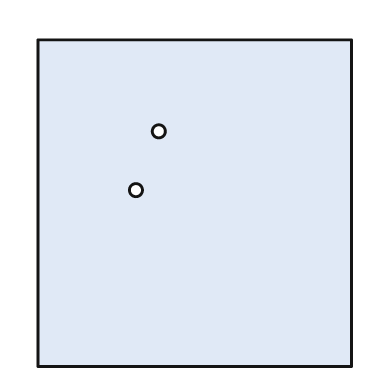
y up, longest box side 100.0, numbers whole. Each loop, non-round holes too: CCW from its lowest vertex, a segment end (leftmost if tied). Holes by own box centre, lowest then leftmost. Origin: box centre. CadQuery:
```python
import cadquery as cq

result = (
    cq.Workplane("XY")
    .moveTo(-48.0, -50.0)
    .lineTo(48.0, -50.0)
    .lineTo(48.0, 50.0)
    .lineTo(-48.0, 50.0)
    .close()
    .moveTo(-18.0, 4.0)
    .circle(2.0)
    .moveTo(-11.0, 22.0)
    .circle(2.0)
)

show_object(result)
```